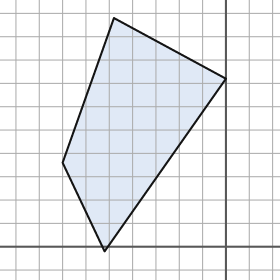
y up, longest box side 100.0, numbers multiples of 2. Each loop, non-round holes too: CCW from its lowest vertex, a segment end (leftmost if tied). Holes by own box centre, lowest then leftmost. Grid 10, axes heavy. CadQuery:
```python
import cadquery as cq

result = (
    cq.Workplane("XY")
    .moveTo(-52.0, -2.0)
    .lineTo(0.0, 72.0)
    .lineTo(-48.0, 98.0)
    .lineTo(-70.0, 36.0)
    .close()
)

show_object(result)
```